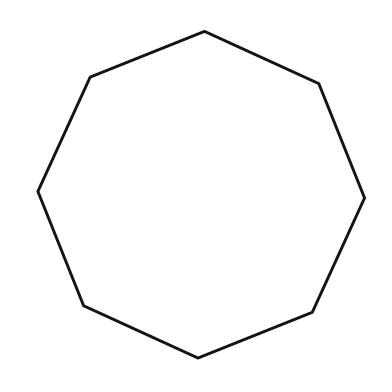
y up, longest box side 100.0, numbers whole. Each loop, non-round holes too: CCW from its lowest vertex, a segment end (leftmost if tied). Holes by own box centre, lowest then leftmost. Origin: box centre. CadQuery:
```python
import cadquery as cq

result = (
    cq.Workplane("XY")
    .moveTo(-1.0, -50.0)
    .lineTo(34.0, -36.0)
    .lineTo(50.0, -1.0)
    .lineTo(36.0, 34.0)
    .lineTo(1.0, 50.0)
    .lineTo(-34.0, 36.0)
    .lineTo(-50.0, 1.0)
    .lineTo(-36.0, -34.0)
    .close()
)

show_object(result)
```